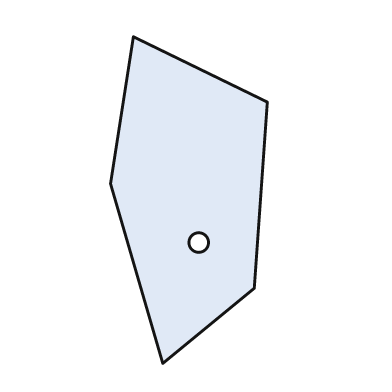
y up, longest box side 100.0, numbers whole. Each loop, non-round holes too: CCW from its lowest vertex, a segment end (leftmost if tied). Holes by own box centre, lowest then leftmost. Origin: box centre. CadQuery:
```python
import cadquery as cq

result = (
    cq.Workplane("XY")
    .moveTo(-8.0, -50.0)
    .lineTo(20.0, -27.0)
    .lineTo(24.0, 30.0)
    .lineTo(-17.0, 50.0)
    .lineTo(-24.0, 5.0)
    .close()
    .moveTo(3.0, -13.0)
    .circle(3.0)
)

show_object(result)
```